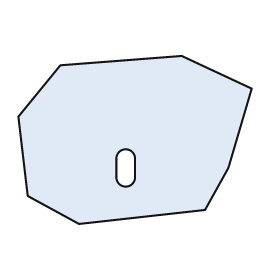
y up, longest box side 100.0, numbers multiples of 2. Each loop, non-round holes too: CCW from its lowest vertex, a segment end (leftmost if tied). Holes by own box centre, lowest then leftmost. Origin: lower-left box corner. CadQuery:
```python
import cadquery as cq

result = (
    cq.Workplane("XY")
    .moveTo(26.0, 0.0)
    .lineTo(80.0, 6.0)
    .lineTo(90.0, 24.0)
    .lineTo(100.0, 58.0)
    .lineTo(70.0, 72.0)
    .lineTo(18.0, 68.0)
    .lineTo(0.0, 46.0)
    .lineTo(4.0, 12.0)
    .close()
    .moveTo(42.0, 20.0)
    .threePointArc((46.0, 16.0), (50.0, 20.0))
    .lineTo(50.0, 28.0)
    .threePointArc((46.0, 32.0), (42.0, 28.0))
    .close()
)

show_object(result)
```